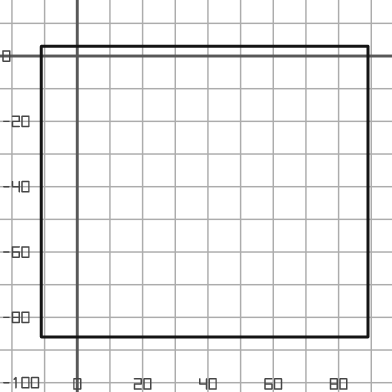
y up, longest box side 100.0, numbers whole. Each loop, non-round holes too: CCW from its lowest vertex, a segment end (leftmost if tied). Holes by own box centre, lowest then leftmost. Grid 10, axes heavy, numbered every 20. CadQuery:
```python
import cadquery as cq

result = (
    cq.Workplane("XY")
    .moveTo(-11.0, -86.0)
    .lineTo(89.0, -86.0)
    .lineTo(89.0, 3.0)
    .lineTo(-11.0, 3.0)
    .close()
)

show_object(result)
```